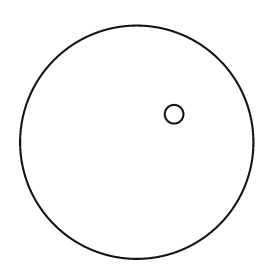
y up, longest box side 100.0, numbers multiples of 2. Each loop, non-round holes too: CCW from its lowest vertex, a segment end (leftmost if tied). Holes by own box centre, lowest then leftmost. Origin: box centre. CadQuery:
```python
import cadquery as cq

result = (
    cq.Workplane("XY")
    .moveTo(0.0, 0.0)
    .circle(50.0)
    .moveTo(16.0, 12.0)
    .circle(4.0)
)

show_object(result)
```